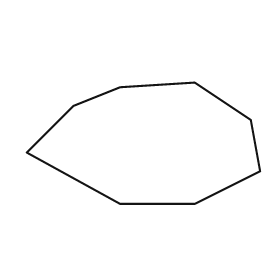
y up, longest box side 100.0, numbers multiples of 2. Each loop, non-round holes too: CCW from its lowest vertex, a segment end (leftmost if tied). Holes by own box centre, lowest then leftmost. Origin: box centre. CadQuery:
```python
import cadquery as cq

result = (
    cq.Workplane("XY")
    .moveTo(-10.0, -26.0)
    .lineTo(22.0, -26.0)
    .lineTo(50.0, -12.0)
    .lineTo(46.0, 10.0)
    .lineTo(22.0, 26.0)
    .lineTo(-10.0, 24.0)
    .lineTo(-30.0, 16.0)
    .lineTo(-50.0, -4.0)
    .close()
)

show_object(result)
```